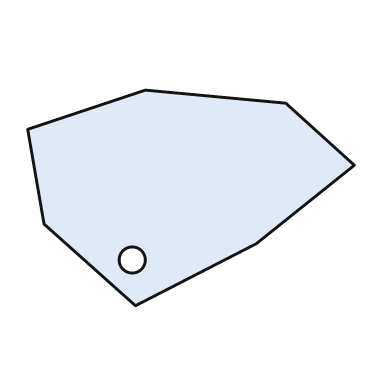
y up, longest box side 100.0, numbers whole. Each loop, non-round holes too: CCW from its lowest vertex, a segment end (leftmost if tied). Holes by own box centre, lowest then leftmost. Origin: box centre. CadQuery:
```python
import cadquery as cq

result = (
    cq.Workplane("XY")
    .moveTo(-17.0, -33.0)
    .lineTo(20.0, -14.0)
    .lineTo(50.0, 10.0)
    .lineTo(29.0, 29.0)
    .lineTo(-14.0, 33.0)
    .lineTo(-50.0, 21.0)
    .lineTo(-45.0, -8.0)
    .close()
    .moveTo(-18.0, -19.0)
    .circle(4.0)
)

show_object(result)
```